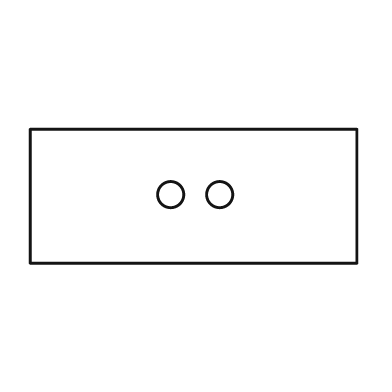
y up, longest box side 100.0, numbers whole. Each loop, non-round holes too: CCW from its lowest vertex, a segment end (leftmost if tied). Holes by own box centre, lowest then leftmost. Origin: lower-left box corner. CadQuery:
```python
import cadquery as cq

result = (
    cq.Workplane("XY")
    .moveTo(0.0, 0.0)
    .lineTo(100.0, 0.0)
    .lineTo(100.0, 41.0)
    .lineTo(0.0, 41.0)
    .close()
    .moveTo(43.0, 21.0)
    .circle(4.0)
    .moveTo(58.0, 21.0)
    .circle(4.0)
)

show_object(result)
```